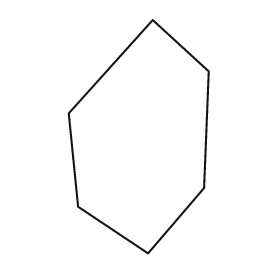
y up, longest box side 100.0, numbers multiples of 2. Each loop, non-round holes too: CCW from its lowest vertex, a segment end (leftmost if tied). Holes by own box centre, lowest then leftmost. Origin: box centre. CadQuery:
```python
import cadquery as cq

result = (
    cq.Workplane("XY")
    .moveTo(4.0, -50.0)
    .lineTo(28.0, -22.0)
    .lineTo(30.0, 28.0)
    .lineTo(6.0, 50.0)
    .lineTo(-30.0, 10.0)
    .lineTo(-26.0, -30.0)
    .close()
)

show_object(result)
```